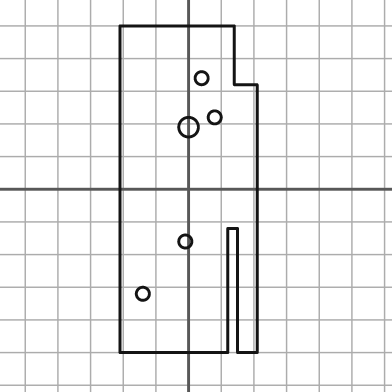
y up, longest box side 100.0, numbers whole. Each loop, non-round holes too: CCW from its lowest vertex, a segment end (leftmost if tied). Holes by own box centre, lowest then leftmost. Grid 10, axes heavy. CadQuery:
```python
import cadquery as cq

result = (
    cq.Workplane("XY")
    .moveTo(-21.0, -50.0)
    .lineTo(12.0, -50.0)
    .lineTo(12.0, -12.0)
    .lineTo(15.0, -12.0)
    .lineTo(15.0, -50.0)
    .lineTo(21.0, -50.0)
    .lineTo(21.0, 32.0)
    .lineTo(14.0, 32.0)
    .lineTo(14.0, 50.0)
    .lineTo(-21.0, 50.0)
    .close()
    .moveTo(-14.0, -32.0)
    .circle(2.0)
    .moveTo(-1.0, -16.0)
    .circle(2.0)
    .moveTo(0.0, 19.0)
    .circle(3.0)
    .moveTo(8.0, 22.0)
    .circle(2.0)
    .moveTo(4.0, 34.0)
    .circle(2.0)
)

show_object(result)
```